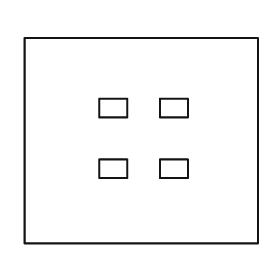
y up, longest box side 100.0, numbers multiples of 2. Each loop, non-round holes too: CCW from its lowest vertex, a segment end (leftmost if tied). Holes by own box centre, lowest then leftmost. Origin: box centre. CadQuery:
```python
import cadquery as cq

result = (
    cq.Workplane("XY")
    .moveTo(-50.0, -44.0)
    .lineTo(50.0, -44.0)
    .lineTo(50.0, 44.0)
    .lineTo(-50.0, 44.0)
    .close()
    .moveTo(-18.0, -16.0)
    .lineTo(-6.0, -16.0)
    .lineTo(-6.0, -8.0)
    .lineTo(-18.0, -8.0)
    .close()
    .moveTo(8.0, -16.0)
    .lineTo(20.0, -16.0)
    .lineTo(20.0, -8.0)
    .lineTo(8.0, -8.0)
    .close()
    .moveTo(-18.0, 10.0)
    .lineTo(-6.0, 10.0)
    .lineTo(-6.0, 18.0)
    .lineTo(-18.0, 18.0)
    .close()
    .moveTo(8.0, 10.0)
    .lineTo(20.0, 10.0)
    .lineTo(20.0, 18.0)
    .lineTo(8.0, 18.0)
    .close()
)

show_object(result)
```